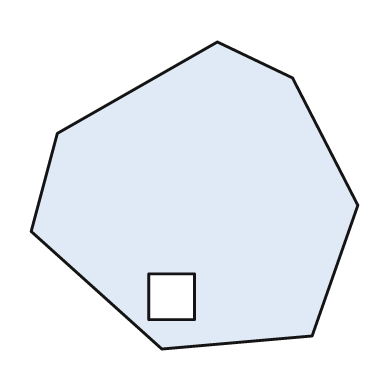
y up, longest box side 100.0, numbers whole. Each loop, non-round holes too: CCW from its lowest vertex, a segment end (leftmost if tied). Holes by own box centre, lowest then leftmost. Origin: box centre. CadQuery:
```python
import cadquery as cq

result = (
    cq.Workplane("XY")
    .moveTo(-10.0, -47.0)
    .lineTo(36.0, -43.0)
    .lineTo(50.0, -3.0)
    .lineTo(30.0, 36.0)
    .lineTo(7.0, 47.0)
    .lineTo(-42.0, 19.0)
    .lineTo(-50.0, -11.0)
    .close()
    .moveTo(-14.0, -38.0)
    .lineTo(0.0, -38.0)
    .lineTo(0.0, -24.0)
    .lineTo(-14.0, -24.0)
    .close()
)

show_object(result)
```